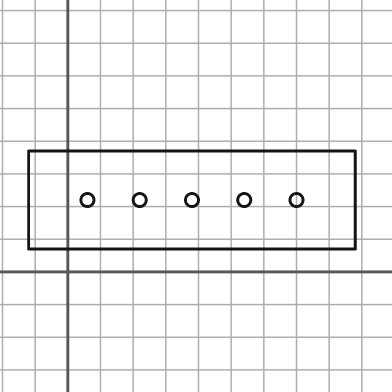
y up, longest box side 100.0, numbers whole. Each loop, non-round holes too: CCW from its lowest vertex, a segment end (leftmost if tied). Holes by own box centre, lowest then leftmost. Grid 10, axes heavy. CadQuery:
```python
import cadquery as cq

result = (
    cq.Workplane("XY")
    .moveTo(-12.0, 7.0)
    .lineTo(88.0, 7.0)
    .lineTo(88.0, 37.0)
    .lineTo(-12.0, 37.0)
    .close()
    .moveTo(6.0, 22.0)
    .circle(2.0)
    .moveTo(22.0, 22.0)
    .circle(2.0)
    .moveTo(38.0, 22.0)
    .circle(2.0)
    .moveTo(54.0, 22.0)
    .circle(2.0)
    .moveTo(70.0, 22.0)
    .circle(2.0)
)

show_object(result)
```